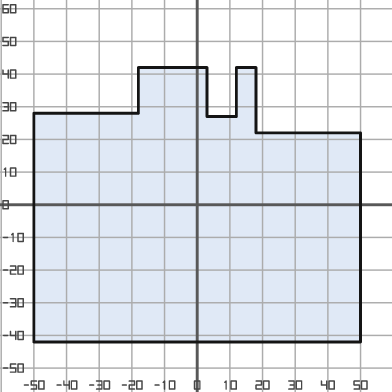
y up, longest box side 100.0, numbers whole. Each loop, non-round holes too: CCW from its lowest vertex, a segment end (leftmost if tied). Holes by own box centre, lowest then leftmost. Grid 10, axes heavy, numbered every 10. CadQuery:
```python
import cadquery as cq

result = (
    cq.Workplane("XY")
    .moveTo(-50.0, -42.0)
    .lineTo(50.0, -42.0)
    .lineTo(50.0, 22.0)
    .lineTo(18.0, 22.0)
    .lineTo(18.0, 42.0)
    .lineTo(12.0, 42.0)
    .lineTo(12.0, 27.0)
    .lineTo(3.0, 27.0)
    .lineTo(3.0, 42.0)
    .lineTo(-18.0, 42.0)
    .lineTo(-18.0, 28.0)
    .lineTo(-50.0, 28.0)
    .close()
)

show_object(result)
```